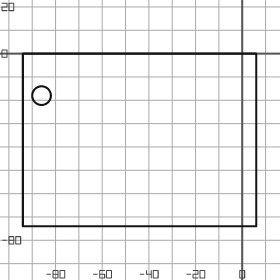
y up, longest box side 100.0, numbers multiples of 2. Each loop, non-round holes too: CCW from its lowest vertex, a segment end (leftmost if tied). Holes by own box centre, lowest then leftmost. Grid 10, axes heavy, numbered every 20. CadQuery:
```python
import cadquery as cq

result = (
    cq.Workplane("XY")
    .moveTo(-94.0, -74.0)
    .lineTo(6.0, -74.0)
    .lineTo(6.0, 0.0)
    .lineTo(-94.0, 0.0)
    .close()
    .moveTo(-86.0, -18.0)
    .circle(4.0)
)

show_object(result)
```